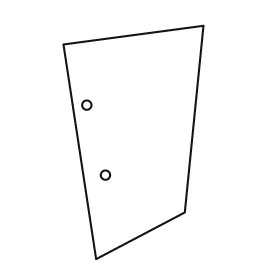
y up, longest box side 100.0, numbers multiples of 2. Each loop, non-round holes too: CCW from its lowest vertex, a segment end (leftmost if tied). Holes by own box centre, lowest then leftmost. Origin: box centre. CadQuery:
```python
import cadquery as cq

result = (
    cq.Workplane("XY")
    .moveTo(-16.0, -50.0)
    .lineTo(22.0, -30.0)
    .lineTo(30.0, 50.0)
    .lineTo(-30.0, 42.0)
    .close()
    .moveTo(-12.0, -14.0)
    .circle(2.0)
    .moveTo(-20.0, 16.0)
    .circle(2.0)
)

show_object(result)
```